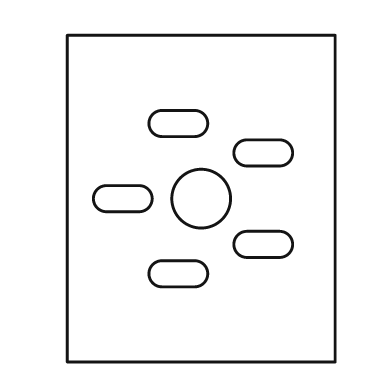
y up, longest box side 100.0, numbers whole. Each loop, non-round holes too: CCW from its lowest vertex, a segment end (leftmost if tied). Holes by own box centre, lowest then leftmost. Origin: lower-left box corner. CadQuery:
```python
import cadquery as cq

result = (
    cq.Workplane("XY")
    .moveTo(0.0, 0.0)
    .lineTo(82.0, 0.0)
    .lineTo(82.0, 100.0)
    .lineTo(0.0, 100.0)
    .close()
    .moveTo(29.0, 23.0)
    .lineTo(39.0, 23.0)
    .threePointArc((43.0, 27.0), (39.0, 31.0))
    .lineTo(29.0, 31.0)
    .threePointArc((25.0, 27.0), (29.0, 23.0))
    .close()
    .moveTo(55.0, 32.0)
    .lineTo(65.0, 32.0)
    .threePointArc((69.0, 36.0), (65.0, 40.0))
    .lineTo(55.0, 40.0)
    .threePointArc((51.0, 36.0), (55.0, 32.0))
    .close()
    .moveTo(12.0, 46.0)
    .lineTo(22.0, 46.0)
    .threePointArc((26.0, 50.0), (22.0, 54.0))
    .lineTo(12.0, 54.0)
    .threePointArc((8.0, 50.0), (12.0, 46.0))
    .close()
    .moveTo(41.0, 50.0)
    .circle(9.0)
    .moveTo(55.0, 60.0)
    .lineTo(65.0, 60.0)
    .threePointArc((69.0, 64.0), (65.0, 68.0))
    .lineTo(55.0, 68.0)
    .threePointArc((51.0, 64.0), (55.0, 60.0))
    .close()
    .moveTo(29.0, 69.0)
    .lineTo(39.0, 69.0)
    .threePointArc((43.0, 73.0), (39.0, 77.0))
    .lineTo(29.0, 77.0)
    .threePointArc((25.0, 73.0), (29.0, 69.0))
    .close()
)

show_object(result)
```